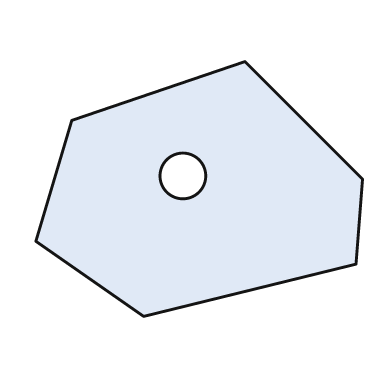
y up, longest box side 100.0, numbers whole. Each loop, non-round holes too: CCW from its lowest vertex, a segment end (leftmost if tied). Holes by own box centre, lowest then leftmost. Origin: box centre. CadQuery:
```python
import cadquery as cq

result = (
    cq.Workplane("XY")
    .moveTo(-17.0, -39.0)
    .lineTo(48.0, -23.0)
    .lineTo(50.0, 3.0)
    .lineTo(14.0, 39.0)
    .lineTo(-39.0, 21.0)
    .lineTo(-50.0, -16.0)
    .close()
    .moveTo(-5.0, 4.0)
    .circle(7.0)
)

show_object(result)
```